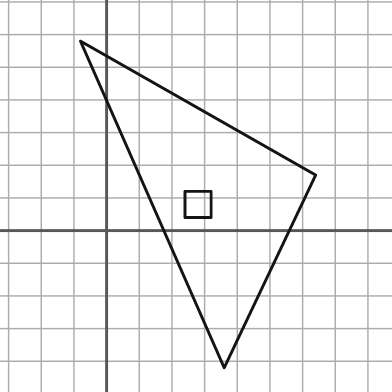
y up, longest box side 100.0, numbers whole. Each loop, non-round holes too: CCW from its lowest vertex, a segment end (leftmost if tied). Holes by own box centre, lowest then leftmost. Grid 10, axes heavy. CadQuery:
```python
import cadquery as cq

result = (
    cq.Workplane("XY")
    .moveTo(36.0, -42.0)
    .lineTo(64.0, 17.0)
    .lineTo(-8.0, 58.0)
    .close()
    .moveTo(24.0, 4.0)
    .lineTo(32.0, 4.0)
    .lineTo(32.0, 12.0)
    .lineTo(24.0, 12.0)
    .close()
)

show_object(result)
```